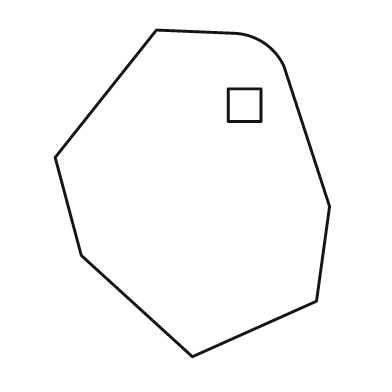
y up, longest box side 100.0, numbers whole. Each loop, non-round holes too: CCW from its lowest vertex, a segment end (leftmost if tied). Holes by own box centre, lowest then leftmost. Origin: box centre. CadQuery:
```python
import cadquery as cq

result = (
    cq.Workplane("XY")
    .moveTo(0.0, -50.0)
    .lineTo(38.0, -33.0)
    .lineTo(42.0, -4.0)
    .lineTo(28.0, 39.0)
    .threePointArc((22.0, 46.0), (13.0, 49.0))
    .lineTo(-11.0, 50.0)
    .lineTo(-42.0, 11.0)
    .lineTo(-34.0, -19.0)
    .close()
    .moveTo(11.0, 22.0)
    .lineTo(21.0, 22.0)
    .lineTo(21.0, 32.0)
    .lineTo(11.0, 32.0)
    .close()
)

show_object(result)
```